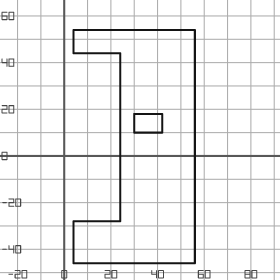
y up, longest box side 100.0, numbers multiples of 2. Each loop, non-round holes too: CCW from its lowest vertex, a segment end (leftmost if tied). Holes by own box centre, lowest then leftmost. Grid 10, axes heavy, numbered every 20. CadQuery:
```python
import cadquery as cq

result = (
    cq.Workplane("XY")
    .moveTo(4.0, -46.0)
    .lineTo(56.0, -46.0)
    .lineTo(56.0, 54.0)
    .lineTo(4.0, 54.0)
    .lineTo(4.0, 44.0)
    .lineTo(24.0, 44.0)
    .lineTo(24.0, -28.0)
    .lineTo(4.0, -28.0)
    .close()
    .moveTo(30.0, 10.0)
    .lineTo(42.0, 10.0)
    .lineTo(42.0, 18.0)
    .lineTo(30.0, 18.0)
    .close()
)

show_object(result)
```